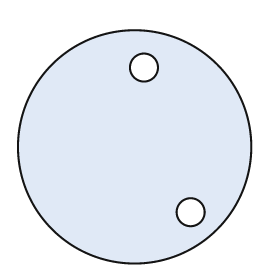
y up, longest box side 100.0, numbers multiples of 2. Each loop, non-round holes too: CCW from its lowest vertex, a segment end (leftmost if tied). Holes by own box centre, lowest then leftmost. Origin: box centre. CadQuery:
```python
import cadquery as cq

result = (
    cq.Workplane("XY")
    .moveTo(0.0, 0.0)
    .circle(50.0)
    .moveTo(24.0, -28.0)
    .circle(6.0)
    .moveTo(4.0, 34.0)
    .circle(6.0)
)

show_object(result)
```